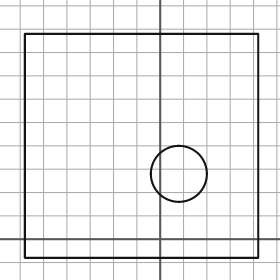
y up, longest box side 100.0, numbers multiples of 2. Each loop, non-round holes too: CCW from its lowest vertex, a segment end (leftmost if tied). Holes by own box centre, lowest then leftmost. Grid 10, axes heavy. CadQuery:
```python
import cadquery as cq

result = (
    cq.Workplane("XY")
    .moveTo(-58.0, -8.0)
    .lineTo(42.0, -8.0)
    .lineTo(42.0, 88.0)
    .lineTo(-58.0, 88.0)
    .close()
    .moveTo(8.0, 28.0)
    .circle(12.0)
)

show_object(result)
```